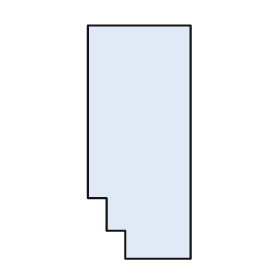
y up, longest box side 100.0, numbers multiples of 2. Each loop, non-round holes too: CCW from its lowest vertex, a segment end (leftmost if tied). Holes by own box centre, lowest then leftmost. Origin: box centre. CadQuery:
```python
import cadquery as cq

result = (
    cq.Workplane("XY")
    .moveTo(-6.0, -50.0)
    .lineTo(22.0, -50.0)
    .lineTo(22.0, 50.0)
    .lineTo(-22.0, 50.0)
    .lineTo(-22.0, -24.0)
    .lineTo(-14.0, -24.0)
    .lineTo(-14.0, -38.0)
    .lineTo(-6.0, -38.0)
    .close()
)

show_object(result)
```